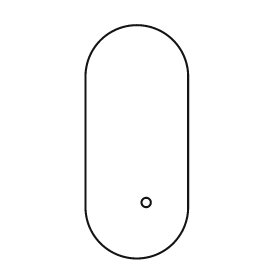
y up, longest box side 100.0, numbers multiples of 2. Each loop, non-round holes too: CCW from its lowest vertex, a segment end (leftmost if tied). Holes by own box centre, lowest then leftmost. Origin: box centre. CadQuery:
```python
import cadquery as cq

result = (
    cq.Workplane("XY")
    .moveTo(-22.0, -28.0)
    .threePointArc((0.0, -50.0), (22.0, -28.0))
    .lineTo(22.0, 28.0)
    .threePointArc((0.0, 50.0), (-22.0, 28.0))
    .close()
    .moveTo(4.0, -26.0)
    .circle(2.0)
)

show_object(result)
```